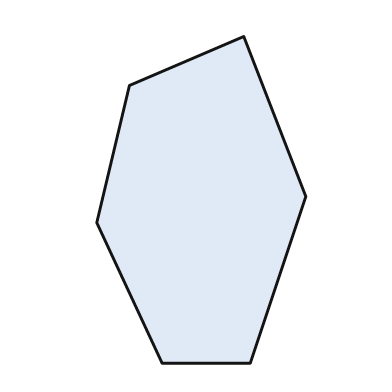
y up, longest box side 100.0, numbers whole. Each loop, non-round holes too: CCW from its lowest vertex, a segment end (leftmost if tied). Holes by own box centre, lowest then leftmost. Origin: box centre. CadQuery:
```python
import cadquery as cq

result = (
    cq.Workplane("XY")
    .moveTo(-12.0, -50.0)
    .lineTo(15.0, -50.0)
    .lineTo(32.0, 1.0)
    .lineTo(13.0, 50.0)
    .lineTo(-22.0, 35.0)
    .lineTo(-32.0, -7.0)
    .close()
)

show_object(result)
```